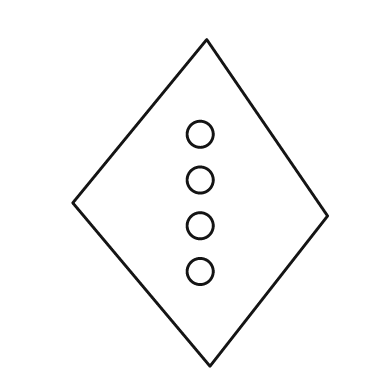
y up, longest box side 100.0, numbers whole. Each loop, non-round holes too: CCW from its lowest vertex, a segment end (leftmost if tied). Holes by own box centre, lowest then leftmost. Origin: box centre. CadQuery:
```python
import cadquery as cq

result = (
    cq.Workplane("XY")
    .moveTo(3.0, -50.0)
    .lineTo(39.0, -4.0)
    .lineTo(2.0, 50.0)
    .lineTo(-39.0, 0.0)
    .close()
    .moveTo(0.0, -21.0)
    .circle(4.0)
    .moveTo(0.0, -7.0)
    .circle(4.0)
    .moveTo(0.0, 7.0)
    .circle(4.0)
    .moveTo(0.0, 21.0)
    .circle(4.0)
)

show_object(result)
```